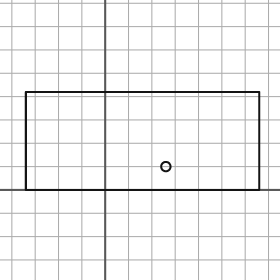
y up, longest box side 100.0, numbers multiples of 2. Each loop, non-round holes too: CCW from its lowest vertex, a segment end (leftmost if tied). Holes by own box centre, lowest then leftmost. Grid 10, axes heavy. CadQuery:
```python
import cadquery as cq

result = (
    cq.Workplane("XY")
    .moveTo(-34.0, 0.0)
    .lineTo(66.0, 0.0)
    .lineTo(66.0, 42.0)
    .lineTo(-34.0, 42.0)
    .close()
    .moveTo(26.0, 10.0)
    .circle(2.0)
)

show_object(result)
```